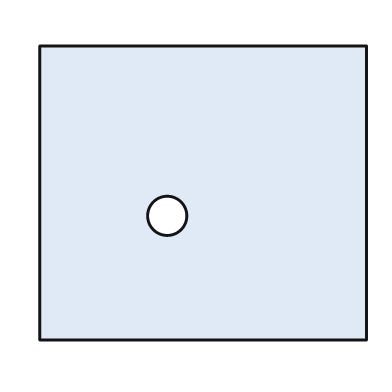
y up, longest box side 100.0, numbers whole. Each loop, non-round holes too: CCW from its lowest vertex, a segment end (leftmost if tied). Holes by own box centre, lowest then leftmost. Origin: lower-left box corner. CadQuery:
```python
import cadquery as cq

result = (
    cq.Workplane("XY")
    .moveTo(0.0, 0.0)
    .lineTo(100.0, 0.0)
    .lineTo(100.0, 90.0)
    .lineTo(0.0, 90.0)
    .close()
    .moveTo(39.0, 38.0)
    .circle(6.0)
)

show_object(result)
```